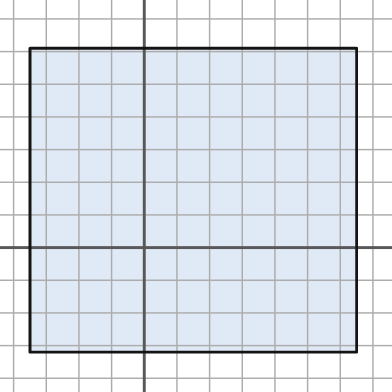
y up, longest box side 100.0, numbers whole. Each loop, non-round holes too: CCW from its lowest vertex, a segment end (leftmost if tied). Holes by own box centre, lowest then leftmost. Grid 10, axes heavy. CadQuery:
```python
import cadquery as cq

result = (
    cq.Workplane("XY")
    .moveTo(-35.0, -32.0)
    .lineTo(65.0, -32.0)
    .lineTo(65.0, 61.0)
    .lineTo(-35.0, 61.0)
    .close()
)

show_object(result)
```